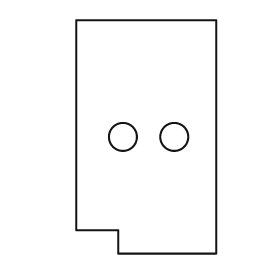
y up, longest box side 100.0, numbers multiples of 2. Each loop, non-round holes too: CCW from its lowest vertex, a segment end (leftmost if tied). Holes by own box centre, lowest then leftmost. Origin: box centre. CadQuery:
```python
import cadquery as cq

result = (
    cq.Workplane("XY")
    .moveTo(-12.0, -50.0)
    .lineTo(30.0, -50.0)
    .lineTo(30.0, 50.0)
    .lineTo(-30.0, 50.0)
    .lineTo(-30.0, -40.0)
    .lineTo(-12.0, -40.0)
    .close()
    .moveTo(-10.0, 0.0)
    .circle(6.0)
    .moveTo(12.0, 0.0)
    .circle(6.0)
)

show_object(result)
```